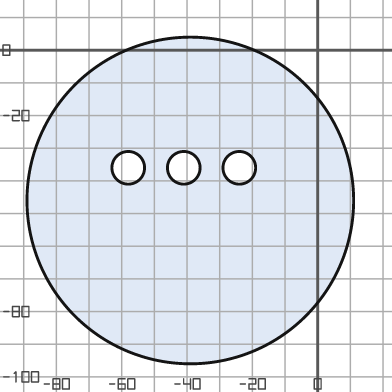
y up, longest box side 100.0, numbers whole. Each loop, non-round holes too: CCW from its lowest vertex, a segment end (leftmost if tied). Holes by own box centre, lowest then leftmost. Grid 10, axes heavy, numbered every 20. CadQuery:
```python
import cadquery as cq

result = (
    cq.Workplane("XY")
    .moveTo(-39.0, -46.0)
    .circle(50.0)
    .moveTo(-58.0, -36.0)
    .circle(5.0)
    .moveTo(-41.0, -36.0)
    .circle(5.0)
    .moveTo(-24.0, -36.0)
    .circle(5.0)
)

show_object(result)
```